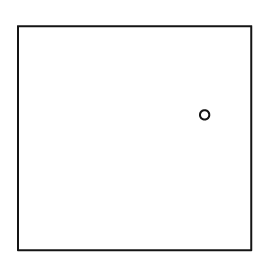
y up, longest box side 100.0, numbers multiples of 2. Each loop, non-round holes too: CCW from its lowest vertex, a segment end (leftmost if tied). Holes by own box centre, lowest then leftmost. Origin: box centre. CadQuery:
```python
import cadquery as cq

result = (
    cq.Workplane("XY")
    .moveTo(-50.0, -48.0)
    .lineTo(50.0, -48.0)
    .lineTo(50.0, 48.0)
    .lineTo(-50.0, 48.0)
    .close()
    .moveTo(30.0, 10.0)
    .circle(2.0)
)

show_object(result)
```